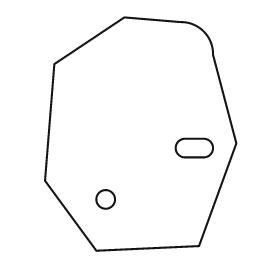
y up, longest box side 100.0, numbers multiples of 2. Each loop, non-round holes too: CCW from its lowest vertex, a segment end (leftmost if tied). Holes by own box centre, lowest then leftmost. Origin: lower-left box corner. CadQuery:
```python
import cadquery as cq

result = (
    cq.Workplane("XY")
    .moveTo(22.0, 0.0)
    .lineTo(66.0, 2.0)
    .lineTo(82.0, 46.0)
    .lineTo(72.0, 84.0)
    .threePointArc((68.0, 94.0), (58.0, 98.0))
    .lineTo(34.0, 100.0)
    .lineTo(4.0, 80.0)
    .lineTo(0.0, 30.0)
    .close()
    .moveTo(26.0, 22.0)
    .circle(4.0)
    .moveTo(60.0, 40.0)
    .lineTo(68.0, 40.0)
    .threePointArc((72.0, 44.0), (68.0, 48.0))
    .lineTo(60.0, 48.0)
    .threePointArc((56.0, 44.0), (60.0, 40.0))
    .close()
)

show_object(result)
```